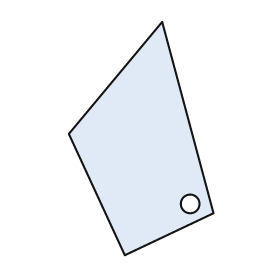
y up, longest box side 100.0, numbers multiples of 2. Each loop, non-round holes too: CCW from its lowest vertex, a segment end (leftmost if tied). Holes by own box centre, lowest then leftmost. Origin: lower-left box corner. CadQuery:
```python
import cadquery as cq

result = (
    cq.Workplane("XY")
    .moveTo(24.0, 0.0)
    .lineTo(62.0, 18.0)
    .lineTo(40.0, 100.0)
    .lineTo(0.0, 52.0)
    .close()
    .moveTo(52.0, 22.0)
    .circle(4.0)
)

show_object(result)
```